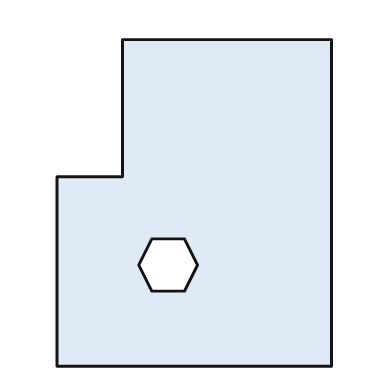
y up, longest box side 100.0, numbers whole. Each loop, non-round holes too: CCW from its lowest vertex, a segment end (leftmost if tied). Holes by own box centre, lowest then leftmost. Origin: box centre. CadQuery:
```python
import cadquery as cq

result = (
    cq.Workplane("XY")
    .moveTo(-42.0, -50.0)
    .lineTo(42.0, -50.0)
    .lineTo(42.0, 50.0)
    .lineTo(-22.0, 50.0)
    .lineTo(-22.0, 8.0)
    .lineTo(-42.0, 8.0)
    .close()
    .moveTo(-13.0, -27.0)
    .lineTo(-3.0, -27.0)
    .lineTo(1.0, -19.0)
    .lineTo(-3.0, -11.0)
    .lineTo(-13.0, -11.0)
    .lineTo(-17.0, -19.0)
    .close()
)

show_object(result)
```